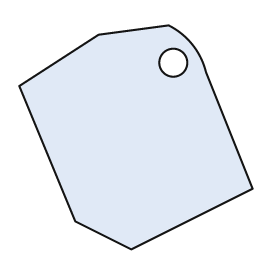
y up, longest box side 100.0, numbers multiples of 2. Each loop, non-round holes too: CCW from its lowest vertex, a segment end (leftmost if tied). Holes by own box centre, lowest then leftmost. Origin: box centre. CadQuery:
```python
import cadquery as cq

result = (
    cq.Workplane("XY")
    .moveTo(-2.0, -48.0)
    .lineTo(50.0, -22.0)
    .lineTo(30.0, 28.0)
    .threePointArc((24.0, 40.0), (14.0, 48.0))
    .lineTo(-16.0, 44.0)
    .lineTo(-50.0, 22.0)
    .lineTo(-26.0, -36.0)
    .close()
    .moveTo(16.0, 32.0)
    .circle(6.0)
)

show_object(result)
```